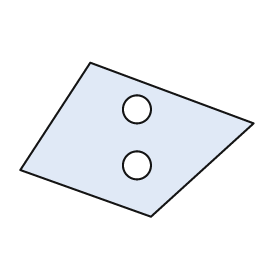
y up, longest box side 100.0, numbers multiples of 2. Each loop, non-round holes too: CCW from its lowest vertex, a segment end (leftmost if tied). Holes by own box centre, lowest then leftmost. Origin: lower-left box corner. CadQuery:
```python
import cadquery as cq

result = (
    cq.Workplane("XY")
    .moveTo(56.0, 0.0)
    .lineTo(100.0, 40.0)
    .lineTo(30.0, 66.0)
    .lineTo(0.0, 20.0)
    .close()
    .moveTo(50.0, 22.0)
    .circle(6.0)
    .moveTo(50.0, 46.0)
    .circle(6.0)
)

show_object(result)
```